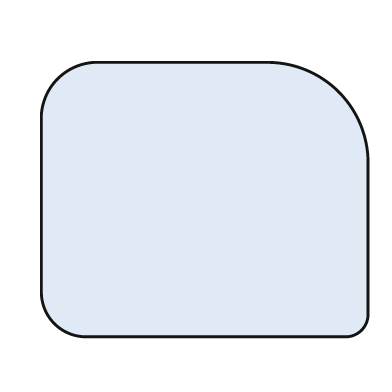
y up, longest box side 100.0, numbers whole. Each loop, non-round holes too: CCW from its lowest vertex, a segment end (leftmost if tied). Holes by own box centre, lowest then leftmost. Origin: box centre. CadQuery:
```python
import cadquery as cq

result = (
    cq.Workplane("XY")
    .moveTo(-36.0, -42.0)
    .lineTo(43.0, -42.0)
    .threePointArc((48.0, -40.0), (50.0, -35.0))
    .lineTo(50.0, 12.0)
    .threePointArc((41.0, 33.0), (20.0, 42.0))
    .lineTo(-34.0, 42.0)
    .threePointArc((-45.0, 37.0), (-50.0, 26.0))
    .lineTo(-50.0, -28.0)
    .threePointArc((-46.0, -38.0), (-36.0, -42.0))
    .close()
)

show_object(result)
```